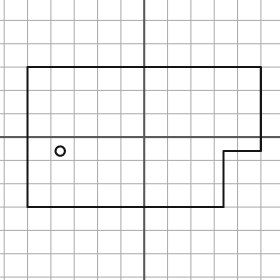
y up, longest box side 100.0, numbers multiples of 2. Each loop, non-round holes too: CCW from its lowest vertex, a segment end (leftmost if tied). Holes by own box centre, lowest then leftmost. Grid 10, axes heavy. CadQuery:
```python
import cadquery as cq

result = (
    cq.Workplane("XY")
    .moveTo(-50.0, -30.0)
    .lineTo(34.0, -30.0)
    .lineTo(34.0, -6.0)
    .lineTo(50.0, -6.0)
    .lineTo(50.0, 30.0)
    .lineTo(-50.0, 30.0)
    .close()
    .moveTo(-36.0, -6.0)
    .circle(2.0)
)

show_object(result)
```